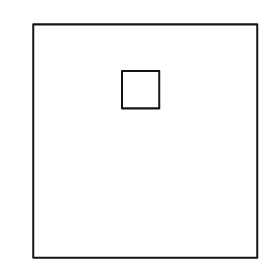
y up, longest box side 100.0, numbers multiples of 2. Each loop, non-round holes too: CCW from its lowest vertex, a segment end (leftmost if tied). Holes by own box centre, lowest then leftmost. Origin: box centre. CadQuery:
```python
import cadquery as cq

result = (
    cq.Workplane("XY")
    .moveTo(-48.0, -50.0)
    .lineTo(48.0, -50.0)
    .lineTo(48.0, 50.0)
    .lineTo(-48.0, 50.0)
    .close()
    .moveTo(-10.0, 14.0)
    .lineTo(6.0, 14.0)
    .lineTo(6.0, 30.0)
    .lineTo(-10.0, 30.0)
    .close()
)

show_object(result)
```